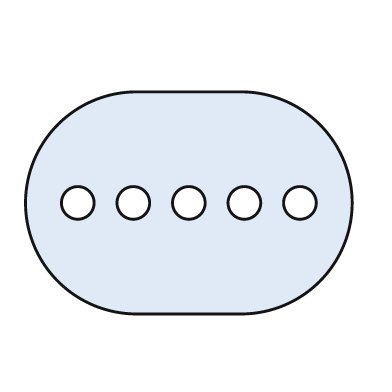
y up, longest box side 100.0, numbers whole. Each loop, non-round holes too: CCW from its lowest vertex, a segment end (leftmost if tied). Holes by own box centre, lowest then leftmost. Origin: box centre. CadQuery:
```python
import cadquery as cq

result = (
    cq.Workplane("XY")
    .moveTo(-16.0, -34.0)
    .lineTo(16.0, -34.0)
    .threePointArc((50.0, 0.0), (16.0, 34.0))
    .lineTo(-16.0, 34.0)
    .threePointArc((-50.0, 0.0), (-16.0, -34.0))
    .close()
    .moveTo(-34.0, 0.0)
    .circle(5.0)
    .moveTo(-17.0, 0.0)
    .circle(5.0)
    .moveTo(0.0, 0.0)
    .circle(5.0)
    .moveTo(17.0, 0.0)
    .circle(5.0)
    .moveTo(34.0, 0.0)
    .circle(5.0)
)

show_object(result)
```